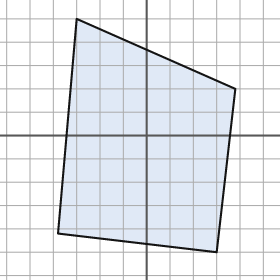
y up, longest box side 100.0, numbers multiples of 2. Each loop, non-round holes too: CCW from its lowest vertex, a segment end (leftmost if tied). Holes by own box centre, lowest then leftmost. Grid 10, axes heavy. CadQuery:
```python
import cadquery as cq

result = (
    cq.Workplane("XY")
    .moveTo(30.0, -50.0)
    .lineTo(38.0, 20.0)
    .lineTo(-30.0, 50.0)
    .lineTo(-38.0, -42.0)
    .close()
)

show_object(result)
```